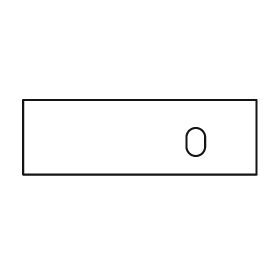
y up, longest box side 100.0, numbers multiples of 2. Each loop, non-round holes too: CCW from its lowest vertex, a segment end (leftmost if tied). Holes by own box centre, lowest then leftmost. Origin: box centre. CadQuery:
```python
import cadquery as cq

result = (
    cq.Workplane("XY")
    .moveTo(-50.0, -16.0)
    .lineTo(50.0, -16.0)
    .lineTo(50.0, 16.0)
    .lineTo(-50.0, 16.0)
    .close()
    .moveTo(20.0, -4.0)
    .threePointArc((24.0, -8.0), (28.0, -4.0))
    .lineTo(28.0, 0.0)
    .threePointArc((24.0, 4.0), (20.0, 0.0))
    .close()
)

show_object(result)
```